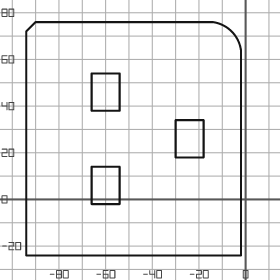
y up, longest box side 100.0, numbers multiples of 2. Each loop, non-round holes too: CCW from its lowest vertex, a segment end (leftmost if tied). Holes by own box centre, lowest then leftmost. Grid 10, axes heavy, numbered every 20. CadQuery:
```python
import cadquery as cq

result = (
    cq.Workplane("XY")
    .moveTo(-94.0, -24.0)
    .lineTo(-2.0, -24.0)
    .lineTo(-2.0, 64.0)
    .threePointArc((-6.0, 72.0), (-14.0, 76.0))
    .lineTo(-90.0, 76.0)
    .lineTo(-94.0, 72.0)
    .close()
    .moveTo(-66.0, -2.0)
    .lineTo(-54.0, -2.0)
    .lineTo(-54.0, 14.0)
    .lineTo(-66.0, 14.0)
    .close()
    .moveTo(-30.0, 18.0)
    .lineTo(-18.0, 18.0)
    .lineTo(-18.0, 34.0)
    .lineTo(-30.0, 34.0)
    .close()
    .moveTo(-66.0, 38.0)
    .lineTo(-54.0, 38.0)
    .lineTo(-54.0, 54.0)
    .lineTo(-66.0, 54.0)
    .close()
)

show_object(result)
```